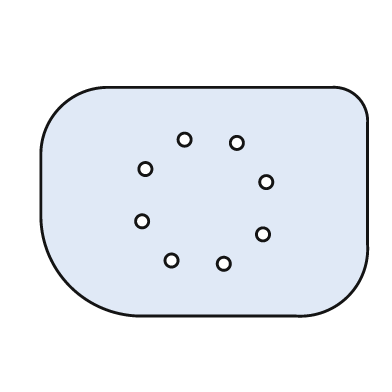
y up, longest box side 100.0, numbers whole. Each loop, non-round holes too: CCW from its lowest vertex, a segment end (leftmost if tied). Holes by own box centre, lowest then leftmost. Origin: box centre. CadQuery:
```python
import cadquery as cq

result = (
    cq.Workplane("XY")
    .moveTo(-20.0, -35.0)
    .lineTo(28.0, -35.0)
    .threePointArc((44.0, -29.0), (50.0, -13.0))
    .lineTo(50.0, 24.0)
    .threePointArc((47.0, 32.0), (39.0, 35.0))
    .lineTo(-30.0, 35.0)
    .threePointArc((-44.0, 29.0), (-50.0, 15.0))
    .lineTo(-50.0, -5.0)
    .threePointArc((-41.0, -26.0), (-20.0, -35.0))
    .close()
    .moveTo(6.0, -19.0)
    .circle(2.0)
    .moveTo(-10.0, -18.0)
    .circle(2.0)
    .moveTo(18.0, -10.0)
    .circle(2.0)
    .moveTo(-19.0, -6.0)
    .circle(2.0)
    .moveTo(19.0, 6.0)
    .circle(2.0)
    .moveTo(-18.0, 10.0)
    .circle(2.0)
    .moveTo(10.0, 18.0)
    .circle(2.0)
    .moveTo(-6.0, 19.0)
    .circle(2.0)
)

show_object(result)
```